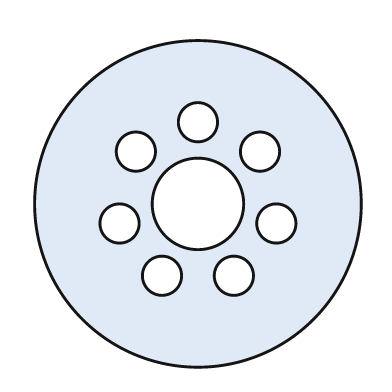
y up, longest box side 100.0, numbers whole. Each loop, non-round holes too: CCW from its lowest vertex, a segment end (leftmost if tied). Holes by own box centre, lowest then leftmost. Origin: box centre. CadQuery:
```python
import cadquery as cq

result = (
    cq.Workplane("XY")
    .moveTo(0.0, 0.0)
    .circle(50.0)
    .moveTo(-11.0, -22.0)
    .circle(6.0)
    .moveTo(11.0, -22.0)
    .circle(6.0)
    .moveTo(-24.0, -6.0)
    .circle(6.0)
    .moveTo(24.0, -6.0)
    .circle(6.0)
    .moveTo(0.0, 0.0)
    .circle(14.0)
    .moveTo(-19.0, 16.0)
    .circle(6.0)
    .moveTo(19.0, 16.0)
    .circle(6.0)
    .moveTo(0.0, 25.0)
    .circle(6.0)
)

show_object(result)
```